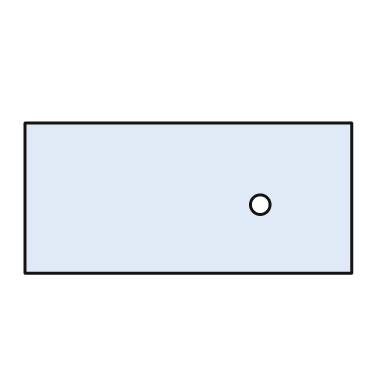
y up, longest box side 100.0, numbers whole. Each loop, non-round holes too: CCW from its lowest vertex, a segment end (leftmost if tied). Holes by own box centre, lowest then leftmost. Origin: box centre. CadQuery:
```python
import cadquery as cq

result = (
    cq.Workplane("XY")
    .moveTo(-50.0, -23.0)
    .lineTo(50.0, -23.0)
    .lineTo(50.0, 23.0)
    .lineTo(-50.0, 23.0)
    .close()
    .moveTo(22.0, -2.0)
    .circle(3.0)
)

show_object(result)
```